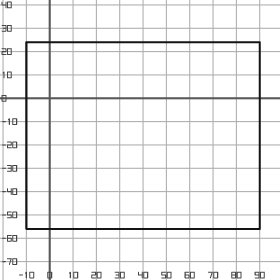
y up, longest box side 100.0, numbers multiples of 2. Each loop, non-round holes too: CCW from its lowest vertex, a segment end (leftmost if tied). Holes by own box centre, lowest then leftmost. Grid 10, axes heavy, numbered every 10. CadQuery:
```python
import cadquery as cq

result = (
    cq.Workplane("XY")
    .moveTo(-10.0, -56.0)
    .lineTo(90.0, -56.0)
    .lineTo(90.0, 24.0)
    .lineTo(-10.0, 24.0)
    .close()
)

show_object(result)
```